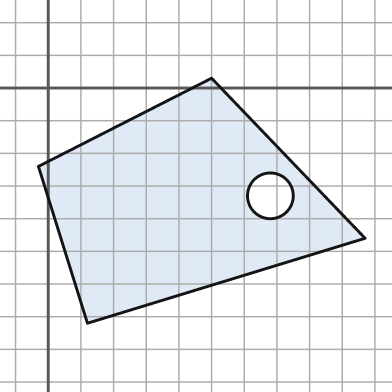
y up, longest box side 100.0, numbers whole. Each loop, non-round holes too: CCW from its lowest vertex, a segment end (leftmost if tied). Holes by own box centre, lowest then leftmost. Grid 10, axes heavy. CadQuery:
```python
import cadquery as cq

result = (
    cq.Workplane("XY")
    .moveTo(12.0, -72.0)
    .lineTo(97.0, -46.0)
    .lineTo(50.0, 3.0)
    .lineTo(-3.0, -24.0)
    .close()
    .moveTo(68.0, -33.0)
    .circle(7.0)
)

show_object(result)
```